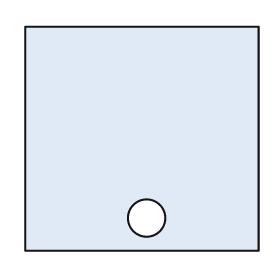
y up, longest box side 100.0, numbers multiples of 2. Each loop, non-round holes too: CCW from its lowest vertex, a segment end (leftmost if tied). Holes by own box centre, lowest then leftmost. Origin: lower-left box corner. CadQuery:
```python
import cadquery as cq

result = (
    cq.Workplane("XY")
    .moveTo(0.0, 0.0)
    .lineTo(100.0, 0.0)
    .lineTo(100.0, 96.0)
    .lineTo(0.0, 96.0)
    .close()
    .moveTo(52.0, 14.0)
    .circle(8.0)
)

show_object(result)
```